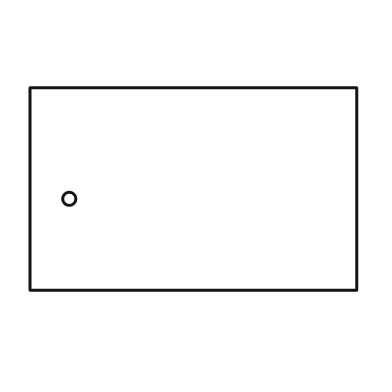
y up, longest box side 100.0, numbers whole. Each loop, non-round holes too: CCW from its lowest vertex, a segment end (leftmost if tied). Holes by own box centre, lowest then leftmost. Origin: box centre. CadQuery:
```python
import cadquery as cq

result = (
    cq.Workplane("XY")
    .moveTo(-50.0, -31.0)
    .lineTo(50.0, -31.0)
    .lineTo(50.0, 31.0)
    .lineTo(-50.0, 31.0)
    .close()
    .moveTo(-38.0, -3.0)
    .circle(2.0)
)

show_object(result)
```